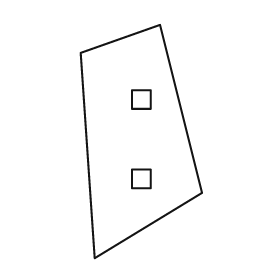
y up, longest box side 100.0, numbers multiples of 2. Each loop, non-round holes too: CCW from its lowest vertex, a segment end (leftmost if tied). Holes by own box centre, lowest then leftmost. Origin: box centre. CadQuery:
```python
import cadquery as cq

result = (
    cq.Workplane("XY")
    .moveTo(-20.0, -50.0)
    .lineTo(26.0, -22.0)
    .lineTo(8.0, 50.0)
    .lineTo(-26.0, 38.0)
    .close()
    .moveTo(-4.0, -20.0)
    .lineTo(4.0, -20.0)
    .lineTo(4.0, -12.0)
    .lineTo(-4.0, -12.0)
    .close()
    .moveTo(-4.0, 14.0)
    .lineTo(4.0, 14.0)
    .lineTo(4.0, 22.0)
    .lineTo(-4.0, 22.0)
    .close()
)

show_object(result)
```